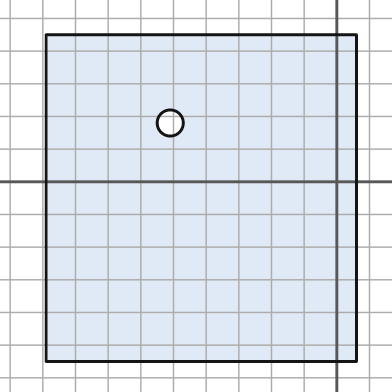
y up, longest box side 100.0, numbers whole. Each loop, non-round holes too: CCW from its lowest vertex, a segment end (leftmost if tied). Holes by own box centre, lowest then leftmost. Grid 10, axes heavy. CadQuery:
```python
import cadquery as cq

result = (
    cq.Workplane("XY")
    .moveTo(-89.0, -55.0)
    .lineTo(6.0, -55.0)
    .lineTo(6.0, 45.0)
    .lineTo(-89.0, 45.0)
    .close()
    .moveTo(-51.0, 18.0)
    .circle(4.0)
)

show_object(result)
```